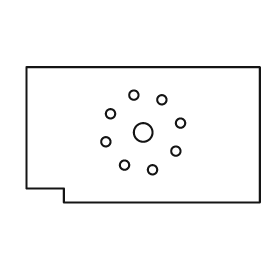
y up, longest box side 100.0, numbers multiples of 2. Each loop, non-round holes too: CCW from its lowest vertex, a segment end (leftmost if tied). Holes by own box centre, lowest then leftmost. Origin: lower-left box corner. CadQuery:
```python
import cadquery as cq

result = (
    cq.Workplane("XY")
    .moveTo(16.0, 0.0)
    .lineTo(100.0, 0.0)
    .lineTo(100.0, 58.0)
    .lineTo(0.0, 58.0)
    .lineTo(0.0, 6.0)
    .lineTo(16.0, 6.0)
    .close()
    .moveTo(54.0, 14.0)
    .circle(2.0)
    .moveTo(42.0, 16.0)
    .circle(2.0)
    .moveTo(64.0, 22.0)
    .circle(2.0)
    .moveTo(34.0, 26.0)
    .circle(2.0)
    .moveTo(50.0, 30.0)
    .circle(4.0)
    .moveTo(66.0, 34.0)
    .circle(2.0)
    .moveTo(36.0, 38.0)
    .circle(2.0)
    .moveTo(58.0, 44.0)
    .circle(2.0)
    .moveTo(46.0, 46.0)
    .circle(2.0)
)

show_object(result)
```